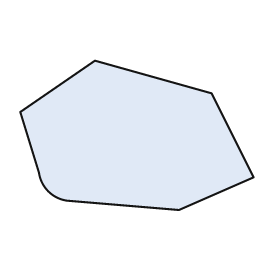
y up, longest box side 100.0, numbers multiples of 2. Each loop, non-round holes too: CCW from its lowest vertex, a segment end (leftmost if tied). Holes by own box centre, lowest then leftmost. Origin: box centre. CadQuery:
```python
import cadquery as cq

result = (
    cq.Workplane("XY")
    .moveTo(18.0, -32.0)
    .lineTo(50.0, -18.0)
    .lineTo(32.0, 18.0)
    .lineTo(-18.0, 32.0)
    .lineTo(-50.0, 10.0)
    .lineTo(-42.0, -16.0)
    .threePointArc((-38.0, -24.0), (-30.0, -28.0))
    .close()
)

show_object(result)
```